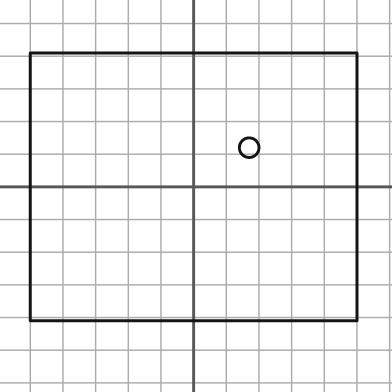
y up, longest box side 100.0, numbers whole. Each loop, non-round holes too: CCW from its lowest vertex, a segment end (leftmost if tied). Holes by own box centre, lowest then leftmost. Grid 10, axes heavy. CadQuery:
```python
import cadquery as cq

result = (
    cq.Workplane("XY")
    .moveTo(-50.0, -41.0)
    .lineTo(50.0, -41.0)
    .lineTo(50.0, 41.0)
    .lineTo(-50.0, 41.0)
    .close()
    .moveTo(17.0, 12.0)
    .circle(3.0)
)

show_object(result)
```